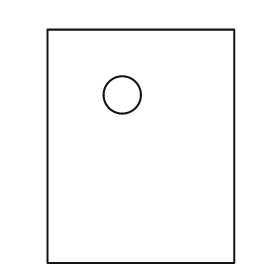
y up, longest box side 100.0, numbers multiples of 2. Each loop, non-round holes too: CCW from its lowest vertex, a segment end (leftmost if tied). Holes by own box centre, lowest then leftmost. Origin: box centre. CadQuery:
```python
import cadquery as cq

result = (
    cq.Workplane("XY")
    .moveTo(-40.0, -50.0)
    .lineTo(40.0, -50.0)
    .lineTo(40.0, 50.0)
    .lineTo(-40.0, 50.0)
    .close()
    .moveTo(-8.0, 22.0)
    .circle(8.0)
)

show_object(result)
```